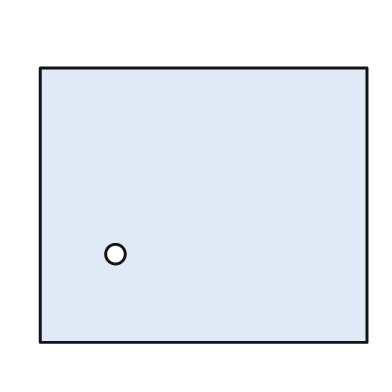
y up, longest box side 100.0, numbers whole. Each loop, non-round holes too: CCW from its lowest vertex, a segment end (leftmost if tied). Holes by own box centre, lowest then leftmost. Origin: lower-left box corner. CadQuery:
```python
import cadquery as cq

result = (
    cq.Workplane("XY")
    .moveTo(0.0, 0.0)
    .lineTo(100.0, 0.0)
    .lineTo(100.0, 84.0)
    .lineTo(0.0, 84.0)
    .close()
    .moveTo(23.0, 27.0)
    .circle(3.0)
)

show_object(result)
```